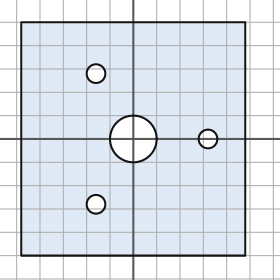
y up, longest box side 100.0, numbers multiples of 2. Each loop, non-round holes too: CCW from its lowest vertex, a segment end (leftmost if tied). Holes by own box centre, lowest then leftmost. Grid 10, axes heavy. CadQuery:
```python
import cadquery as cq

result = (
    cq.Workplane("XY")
    .moveTo(-48.0, -50.0)
    .lineTo(48.0, -50.0)
    .lineTo(48.0, 50.0)
    .lineTo(-48.0, 50.0)
    .close()
    .moveTo(-16.0, -28.0)
    .circle(4.0)
    .moveTo(0.0, 0.0)
    .circle(10.0)
    .moveTo(32.0, 0.0)
    .circle(4.0)
    .moveTo(-16.0, 28.0)
    .circle(4.0)
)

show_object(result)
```